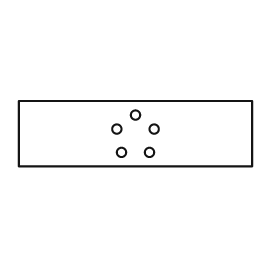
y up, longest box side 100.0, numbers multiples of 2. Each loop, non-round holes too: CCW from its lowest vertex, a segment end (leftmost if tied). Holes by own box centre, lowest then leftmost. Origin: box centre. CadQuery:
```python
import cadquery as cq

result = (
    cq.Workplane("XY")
    .moveTo(-50.0, -14.0)
    .lineTo(50.0, -14.0)
    .lineTo(50.0, 14.0)
    .lineTo(-50.0, 14.0)
    .close()
    .moveTo(-6.0, -8.0)
    .circle(2.0)
    .moveTo(6.0, -8.0)
    .circle(2.0)
    .moveTo(-8.0, 2.0)
    .circle(2.0)
    .moveTo(8.0, 2.0)
    .circle(2.0)
    .moveTo(0.0, 8.0)
    .circle(2.0)
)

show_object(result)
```